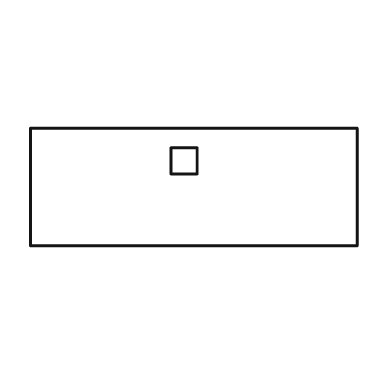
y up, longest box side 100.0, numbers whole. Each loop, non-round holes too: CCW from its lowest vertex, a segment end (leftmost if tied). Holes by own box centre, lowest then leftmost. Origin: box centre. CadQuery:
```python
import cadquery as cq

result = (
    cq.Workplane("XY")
    .moveTo(-50.0, -18.0)
    .lineTo(50.0, -18.0)
    .lineTo(50.0, 18.0)
    .lineTo(-50.0, 18.0)
    .close()
    .moveTo(-7.0, 4.0)
    .lineTo(1.0, 4.0)
    .lineTo(1.0, 12.0)
    .lineTo(-7.0, 12.0)
    .close()
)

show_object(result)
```